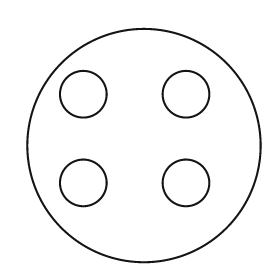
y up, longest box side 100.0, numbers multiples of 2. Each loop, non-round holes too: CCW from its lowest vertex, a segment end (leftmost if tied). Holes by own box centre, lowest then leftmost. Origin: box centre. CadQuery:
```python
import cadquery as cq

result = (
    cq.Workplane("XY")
    .moveTo(0.0, 0.0)
    .circle(50.0)
    .moveTo(-26.0, -16.0)
    .circle(10.0)
    .moveTo(18.0, -16.0)
    .circle(10.0)
    .moveTo(-26.0, 22.0)
    .circle(10.0)
    .moveTo(18.0, 22.0)
    .circle(10.0)
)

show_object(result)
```